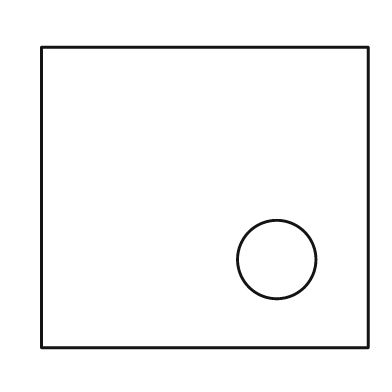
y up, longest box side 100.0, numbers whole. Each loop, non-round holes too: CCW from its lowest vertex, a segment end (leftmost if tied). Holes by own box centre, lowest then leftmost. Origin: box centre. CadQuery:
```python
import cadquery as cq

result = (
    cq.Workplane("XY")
    .moveTo(-50.0, -46.0)
    .lineTo(50.0, -46.0)
    .lineTo(50.0, 46.0)
    .lineTo(-50.0, 46.0)
    .close()
    .moveTo(22.0, -19.0)
    .circle(12.0)
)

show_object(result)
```